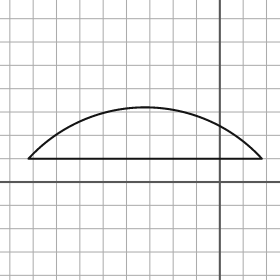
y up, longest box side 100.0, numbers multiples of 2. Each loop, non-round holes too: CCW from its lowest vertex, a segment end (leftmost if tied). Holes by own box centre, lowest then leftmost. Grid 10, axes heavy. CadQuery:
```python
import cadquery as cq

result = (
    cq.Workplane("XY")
    .moveTo(-82.0, 10.0)
    .lineTo(18.0, 10.0)
    .threePointArc((-32.0, 32.0), (-82.0, 10.0))
    .close()
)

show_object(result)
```